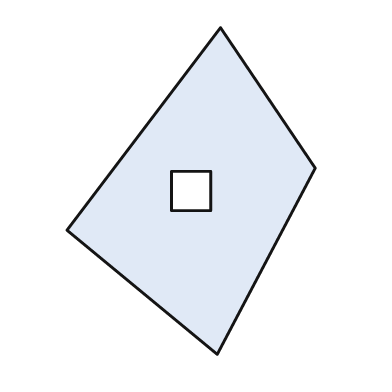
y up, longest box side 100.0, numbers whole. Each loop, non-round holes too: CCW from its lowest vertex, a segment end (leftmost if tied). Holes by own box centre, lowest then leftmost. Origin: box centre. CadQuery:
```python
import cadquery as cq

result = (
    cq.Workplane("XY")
    .moveTo(8.0, -50.0)
    .lineTo(38.0, 7.0)
    .lineTo(9.0, 50.0)
    .lineTo(-38.0, -12.0)
    .close()
    .moveTo(-6.0, -6.0)
    .lineTo(6.0, -6.0)
    .lineTo(6.0, 6.0)
    .lineTo(-6.0, 6.0)
    .close()
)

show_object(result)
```